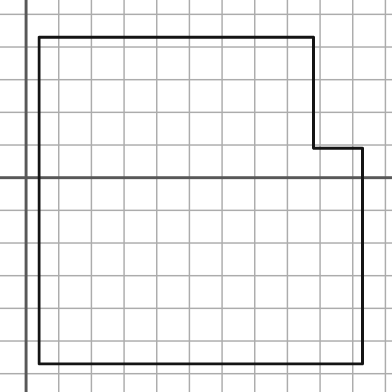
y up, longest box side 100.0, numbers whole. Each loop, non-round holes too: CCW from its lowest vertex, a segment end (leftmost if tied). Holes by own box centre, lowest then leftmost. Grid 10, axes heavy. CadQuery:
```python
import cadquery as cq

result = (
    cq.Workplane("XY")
    .moveTo(4.0, -57.0)
    .lineTo(103.0, -57.0)
    .lineTo(103.0, 9.0)
    .lineTo(88.0, 9.0)
    .lineTo(88.0, 43.0)
    .lineTo(4.0, 43.0)
    .close()
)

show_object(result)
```